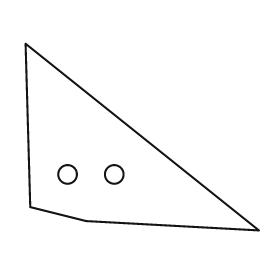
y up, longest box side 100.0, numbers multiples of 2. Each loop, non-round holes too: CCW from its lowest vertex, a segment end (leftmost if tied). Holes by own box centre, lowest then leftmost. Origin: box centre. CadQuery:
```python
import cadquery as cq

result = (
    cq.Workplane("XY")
    .moveTo(50.0, -40.0)
    .lineTo(-50.0, 40.0)
    .lineTo(-48.0, -30.0)
    .lineTo(-24.0, -36.0)
    .close()
    .moveTo(-32.0, -16.0)
    .circle(4.0)
    .moveTo(-12.0, -16.0)
    .circle(4.0)
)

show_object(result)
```